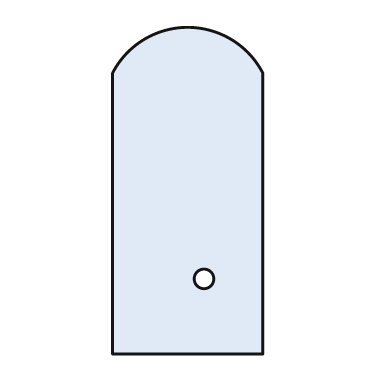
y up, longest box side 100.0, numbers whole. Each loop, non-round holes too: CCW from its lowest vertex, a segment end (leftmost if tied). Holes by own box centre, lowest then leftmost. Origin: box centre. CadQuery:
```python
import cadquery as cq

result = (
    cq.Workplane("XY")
    .moveTo(-23.0, -50.0)
    .lineTo(23.0, -50.0)
    .lineTo(23.0, 36.0)
    .threePointArc((0.0, 50.0), (-23.0, 36.0))
    .close()
    .moveTo(5.0, -27.0)
    .circle(3.0)
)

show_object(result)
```